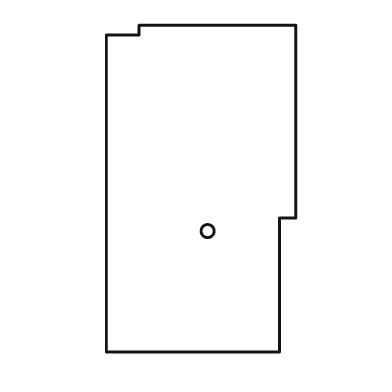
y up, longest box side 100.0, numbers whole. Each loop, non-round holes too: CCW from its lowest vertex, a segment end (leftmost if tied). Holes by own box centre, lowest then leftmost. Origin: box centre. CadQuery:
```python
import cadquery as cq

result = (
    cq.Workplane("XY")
    .moveTo(-29.0, -50.0)
    .lineTo(24.0, -50.0)
    .lineTo(24.0, -9.0)
    .lineTo(29.0, -9.0)
    .lineTo(29.0, 50.0)
    .lineTo(-19.0, 50.0)
    .lineTo(-19.0, 47.0)
    .lineTo(-29.0, 47.0)
    .close()
    .moveTo(2.0, -13.0)
    .circle(2.0)
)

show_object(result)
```